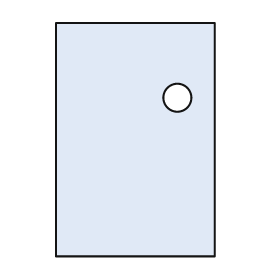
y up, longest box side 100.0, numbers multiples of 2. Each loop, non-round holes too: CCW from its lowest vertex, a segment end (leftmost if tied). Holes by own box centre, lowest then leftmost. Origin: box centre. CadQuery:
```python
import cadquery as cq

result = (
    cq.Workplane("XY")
    .moveTo(-34.0, -50.0)
    .lineTo(34.0, -50.0)
    .lineTo(34.0, 50.0)
    .lineTo(-34.0, 50.0)
    .close()
    .moveTo(18.0, 18.0)
    .circle(6.0)
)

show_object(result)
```